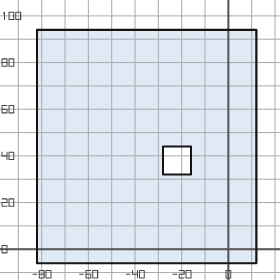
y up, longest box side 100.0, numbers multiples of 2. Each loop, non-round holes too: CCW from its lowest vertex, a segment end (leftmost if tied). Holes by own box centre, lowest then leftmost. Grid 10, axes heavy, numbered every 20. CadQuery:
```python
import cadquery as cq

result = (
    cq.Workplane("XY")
    .moveTo(-82.0, -6.0)
    .lineTo(12.0, -6.0)
    .lineTo(12.0, 94.0)
    .lineTo(-82.0, 94.0)
    .close()
    .moveTo(-28.0, 32.0)
    .lineTo(-16.0, 32.0)
    .lineTo(-16.0, 44.0)
    .lineTo(-28.0, 44.0)
    .close()
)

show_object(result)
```